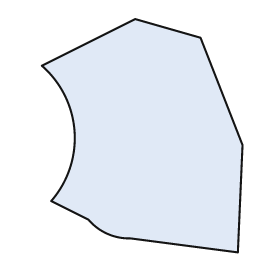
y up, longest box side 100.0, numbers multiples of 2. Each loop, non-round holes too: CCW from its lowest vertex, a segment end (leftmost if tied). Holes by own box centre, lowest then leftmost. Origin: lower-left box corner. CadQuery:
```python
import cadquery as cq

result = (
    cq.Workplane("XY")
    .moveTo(84.0, 0.0)
    .lineTo(86.0, 46.0)
    .lineTo(68.0, 92.0)
    .lineTo(40.0, 100.0)
    .lineTo(0.0, 80.0)
    .threePointArc((14.0, 52.0), (4.0, 22.0))
    .lineTo(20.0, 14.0)
    .threePointArc((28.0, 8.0), (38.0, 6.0))
    .close()
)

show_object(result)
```